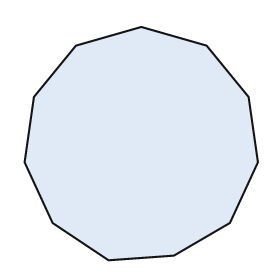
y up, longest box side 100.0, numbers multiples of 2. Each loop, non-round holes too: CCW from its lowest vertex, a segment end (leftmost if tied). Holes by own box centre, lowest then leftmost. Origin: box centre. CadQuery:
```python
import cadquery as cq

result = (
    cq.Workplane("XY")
    .moveTo(-14.0, -50.0)
    .lineTo(14.0, -48.0)
    .lineTo(38.0, -34.0)
    .lineTo(50.0, -8.0)
    .lineTo(46.0, 20.0)
    .lineTo(28.0, 42.0)
    .lineTo(0.0, 50.0)
    .lineTo(-28.0, 42.0)
    .lineTo(-46.0, 20.0)
    .lineTo(-50.0, -8.0)
    .lineTo(-38.0, -34.0)
    .close()
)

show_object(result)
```